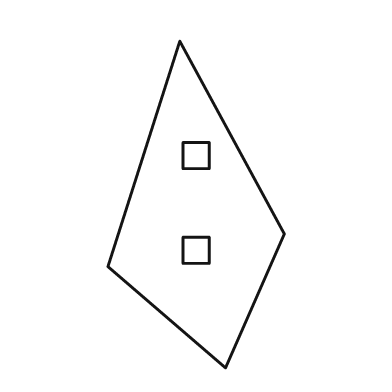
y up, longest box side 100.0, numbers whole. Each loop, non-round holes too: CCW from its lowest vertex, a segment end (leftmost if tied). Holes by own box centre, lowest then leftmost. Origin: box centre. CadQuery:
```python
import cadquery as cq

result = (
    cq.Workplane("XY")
    .moveTo(9.0, -50.0)
    .lineTo(27.0, -9.0)
    .lineTo(-5.0, 50.0)
    .lineTo(-27.0, -19.0)
    .close()
    .moveTo(-4.0, -18.0)
    .lineTo(4.0, -18.0)
    .lineTo(4.0, -10.0)
    .lineTo(-4.0, -10.0)
    .close()
    .moveTo(-4.0, 11.0)
    .lineTo(4.0, 11.0)
    .lineTo(4.0, 19.0)
    .lineTo(-4.0, 19.0)
    .close()
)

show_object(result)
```